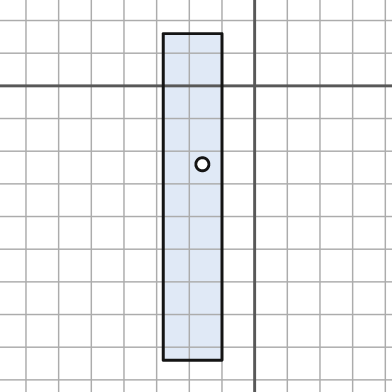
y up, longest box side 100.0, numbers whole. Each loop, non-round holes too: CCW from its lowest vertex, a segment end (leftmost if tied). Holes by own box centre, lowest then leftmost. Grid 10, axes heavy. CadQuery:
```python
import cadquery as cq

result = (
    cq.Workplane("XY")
    .moveTo(-28.0, -84.0)
    .lineTo(-10.0, -84.0)
    .lineTo(-10.0, 16.0)
    .lineTo(-28.0, 16.0)
    .close()
    .moveTo(-16.0, -24.0)
    .circle(2.0)
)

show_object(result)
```